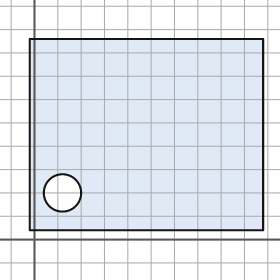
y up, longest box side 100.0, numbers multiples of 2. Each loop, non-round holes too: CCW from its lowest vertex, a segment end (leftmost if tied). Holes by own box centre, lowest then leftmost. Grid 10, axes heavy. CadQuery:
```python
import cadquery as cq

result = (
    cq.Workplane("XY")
    .moveTo(-2.0, 4.0)
    .lineTo(98.0, 4.0)
    .lineTo(98.0, 86.0)
    .lineTo(-2.0, 86.0)
    .close()
    .moveTo(12.0, 20.0)
    .circle(8.0)
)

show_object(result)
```